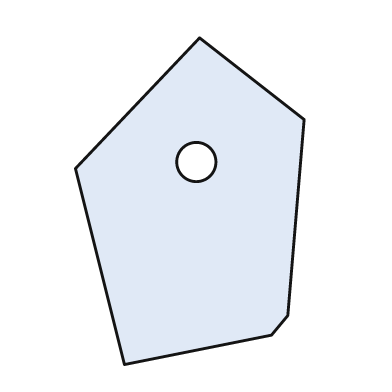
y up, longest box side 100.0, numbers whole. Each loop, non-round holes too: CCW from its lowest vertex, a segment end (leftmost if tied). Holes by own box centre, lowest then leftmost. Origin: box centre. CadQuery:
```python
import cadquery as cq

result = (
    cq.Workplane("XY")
    .moveTo(-20.0, -50.0)
    .lineTo(25.0, -41.0)
    .lineTo(30.0, -35.0)
    .lineTo(35.0, 25.0)
    .lineTo(3.0, 50.0)
    .lineTo(-35.0, 10.0)
    .close()
    .moveTo(2.0, 12.0)
    .circle(6.0)
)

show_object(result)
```